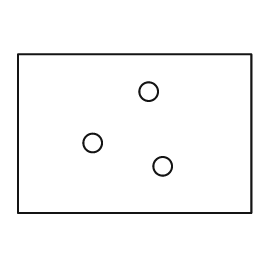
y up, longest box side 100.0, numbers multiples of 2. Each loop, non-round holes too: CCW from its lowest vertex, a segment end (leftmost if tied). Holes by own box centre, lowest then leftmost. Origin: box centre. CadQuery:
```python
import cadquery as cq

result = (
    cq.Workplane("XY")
    .moveTo(-50.0, -34.0)
    .lineTo(50.0, -34.0)
    .lineTo(50.0, 34.0)
    .lineTo(-50.0, 34.0)
    .close()
    .moveTo(12.0, -14.0)
    .circle(4.0)
    .moveTo(-18.0, -4.0)
    .circle(4.0)
    .moveTo(6.0, 18.0)
    .circle(4.0)
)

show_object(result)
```